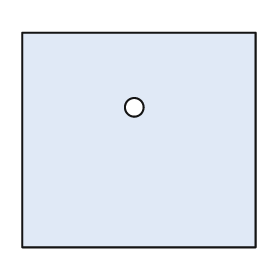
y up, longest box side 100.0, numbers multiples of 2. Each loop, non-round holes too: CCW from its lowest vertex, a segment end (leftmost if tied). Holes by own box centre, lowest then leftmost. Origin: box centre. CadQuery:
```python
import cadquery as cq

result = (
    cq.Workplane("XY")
    .moveTo(-50.0, -46.0)
    .lineTo(50.0, -46.0)
    .lineTo(50.0, 46.0)
    .lineTo(-50.0, 46.0)
    .close()
    .moveTo(-2.0, 14.0)
    .circle(4.0)
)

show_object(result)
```